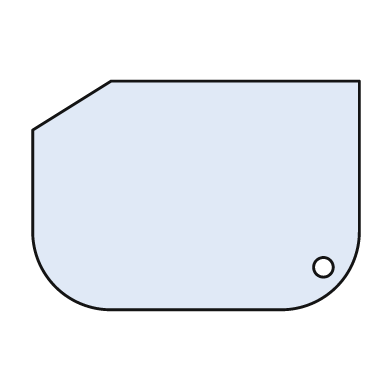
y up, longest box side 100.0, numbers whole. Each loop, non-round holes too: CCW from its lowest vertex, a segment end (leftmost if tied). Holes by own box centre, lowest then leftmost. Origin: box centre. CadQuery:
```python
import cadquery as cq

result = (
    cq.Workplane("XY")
    .moveTo(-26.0, -35.0)
    .lineTo(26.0, -35.0)
    .threePointArc((43.0, -28.0), (50.0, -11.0))
    .lineTo(50.0, 35.0)
    .lineTo(-26.0, 35.0)
    .lineTo(-50.0, 20.0)
    .lineTo(-50.0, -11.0)
    .threePointArc((-43.0, -28.0), (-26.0, -35.0))
    .close()
    .moveTo(39.0, -22.0)
    .circle(3.0)
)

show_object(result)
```